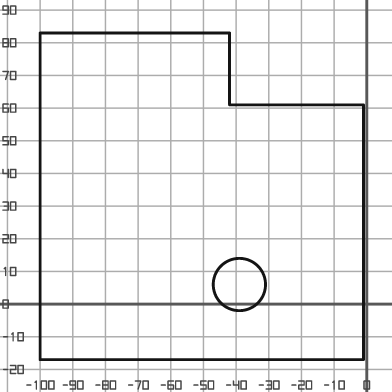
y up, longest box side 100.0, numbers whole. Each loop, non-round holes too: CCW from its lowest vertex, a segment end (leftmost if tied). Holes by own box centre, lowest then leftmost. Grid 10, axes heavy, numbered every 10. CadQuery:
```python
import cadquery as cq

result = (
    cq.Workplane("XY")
    .moveTo(-100.0, -17.0)
    .lineTo(-1.0, -17.0)
    .lineTo(-1.0, 61.0)
    .lineTo(-42.0, 61.0)
    .lineTo(-42.0, 83.0)
    .lineTo(-100.0, 83.0)
    .close()
    .moveTo(-39.0, 6.0)
    .circle(8.0)
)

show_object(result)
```